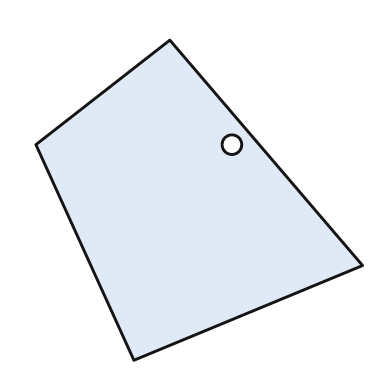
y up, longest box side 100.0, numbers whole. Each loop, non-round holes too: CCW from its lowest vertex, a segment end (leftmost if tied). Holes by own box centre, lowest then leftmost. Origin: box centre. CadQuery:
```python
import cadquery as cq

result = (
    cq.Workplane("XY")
    .moveTo(-20.0, -49.0)
    .lineTo(50.0, -20.0)
    .lineTo(-9.0, 49.0)
    .lineTo(-50.0, 17.0)
    .close()
    .moveTo(10.0, 17.0)
    .circle(3.0)
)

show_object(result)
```